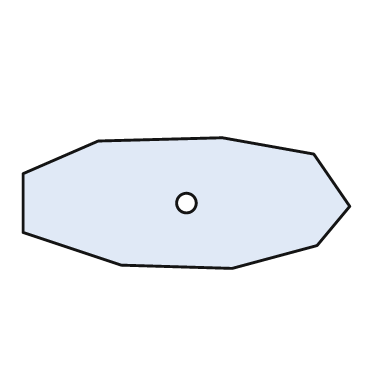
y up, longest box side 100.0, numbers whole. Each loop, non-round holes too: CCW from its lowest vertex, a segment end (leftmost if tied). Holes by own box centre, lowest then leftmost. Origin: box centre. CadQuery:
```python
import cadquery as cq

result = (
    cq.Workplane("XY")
    .moveTo(14.0, -20.0)
    .lineTo(40.0, -13.0)
    .lineTo(50.0, -1.0)
    .lineTo(39.0, 15.0)
    .lineTo(11.0, 20.0)
    .lineTo(-27.0, 19.0)
    .lineTo(-50.0, 9.0)
    .lineTo(-50.0, -9.0)
    .lineTo(-20.0, -19.0)
    .close()
    .moveTo(0.0, 0.0)
    .circle(3.0)
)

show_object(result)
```